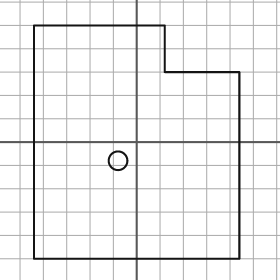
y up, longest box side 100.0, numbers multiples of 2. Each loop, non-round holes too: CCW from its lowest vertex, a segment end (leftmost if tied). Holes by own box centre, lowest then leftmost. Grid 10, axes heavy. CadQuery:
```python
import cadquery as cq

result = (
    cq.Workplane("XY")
    .moveTo(-44.0, -50.0)
    .lineTo(44.0, -50.0)
    .lineTo(44.0, 30.0)
    .lineTo(12.0, 30.0)
    .lineTo(12.0, 50.0)
    .lineTo(-44.0, 50.0)
    .close()
    .moveTo(-8.0, -8.0)
    .circle(4.0)
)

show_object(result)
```